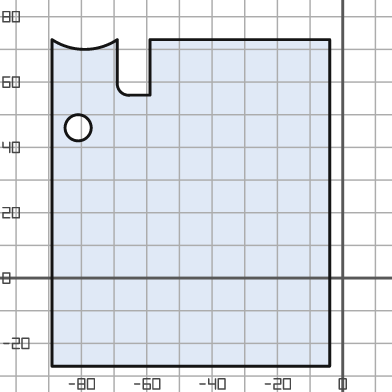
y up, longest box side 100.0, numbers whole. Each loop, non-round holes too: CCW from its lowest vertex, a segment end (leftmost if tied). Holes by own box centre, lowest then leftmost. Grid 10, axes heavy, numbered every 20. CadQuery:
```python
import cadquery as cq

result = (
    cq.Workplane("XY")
    .moveTo(-89.0, -27.0)
    .lineTo(-4.0, -27.0)
    .lineTo(-4.0, 73.0)
    .lineTo(-59.0, 73.0)
    .lineTo(-59.0, 56.0)
    .lineTo(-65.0, 56.0)
    .threePointArc((-68.0, 57.0), (-69.0, 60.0))
    .lineTo(-69.0, 73.0)
    .threePointArc((-79.0, 70.0), (-89.0, 73.0))
    .close()
    .moveTo(-81.0, 46.0)
    .circle(4.0)
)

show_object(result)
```